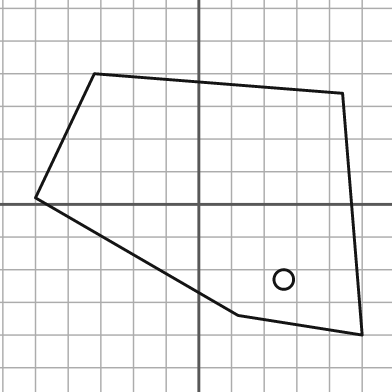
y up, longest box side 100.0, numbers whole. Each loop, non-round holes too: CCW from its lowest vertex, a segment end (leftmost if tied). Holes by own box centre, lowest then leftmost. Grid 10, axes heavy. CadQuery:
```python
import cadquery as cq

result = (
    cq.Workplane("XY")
    .moveTo(50.0, -40.0)
    .lineTo(44.0, 34.0)
    .lineTo(-32.0, 40.0)
    .lineTo(-50.0, 2.0)
    .lineTo(12.0, -34.0)
    .close()
    .moveTo(26.0, -23.0)
    .circle(3.0)
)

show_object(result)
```